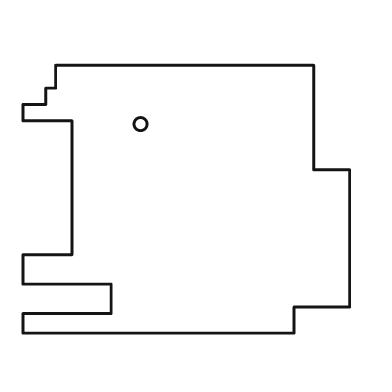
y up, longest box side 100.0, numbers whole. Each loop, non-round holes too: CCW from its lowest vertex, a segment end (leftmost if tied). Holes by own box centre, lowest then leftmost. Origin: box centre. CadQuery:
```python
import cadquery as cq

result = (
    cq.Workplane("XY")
    .moveTo(-50.0, -41.0)
    .lineTo(33.0, -41.0)
    .lineTo(33.0, -33.0)
    .lineTo(50.0, -33.0)
    .lineTo(50.0, 9.0)
    .lineTo(39.0, 9.0)
    .lineTo(39.0, 41.0)
    .lineTo(-40.0, 41.0)
    .lineTo(-40.0, 34.0)
    .lineTo(-43.0, 34.0)
    .lineTo(-43.0, 29.0)
    .lineTo(-50.0, 29.0)
    .lineTo(-50.0, 24.0)
    .lineTo(-35.0, 24.0)
    .lineTo(-35.0, -17.0)
    .lineTo(-50.0, -17.0)
    .lineTo(-50.0, -26.0)
    .lineTo(-23.0, -26.0)
    .lineTo(-23.0, -35.0)
    .lineTo(-50.0, -35.0)
    .close()
    .moveTo(-14.0, 23.0)
    .circle(2.0)
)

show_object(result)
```